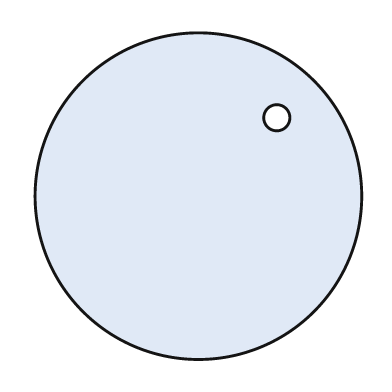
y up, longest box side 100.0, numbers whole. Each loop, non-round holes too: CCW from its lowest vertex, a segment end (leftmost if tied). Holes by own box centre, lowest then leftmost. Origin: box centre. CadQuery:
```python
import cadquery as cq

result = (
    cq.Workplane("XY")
    .moveTo(0.0, 0.0)
    .circle(50.0)
    .moveTo(24.0, 24.0)
    .circle(4.0)
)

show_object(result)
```